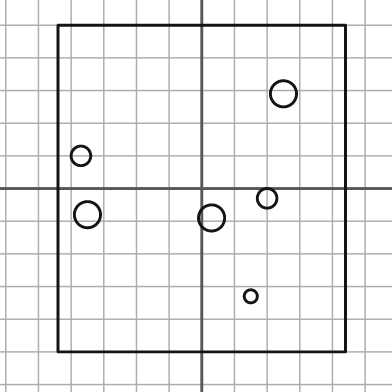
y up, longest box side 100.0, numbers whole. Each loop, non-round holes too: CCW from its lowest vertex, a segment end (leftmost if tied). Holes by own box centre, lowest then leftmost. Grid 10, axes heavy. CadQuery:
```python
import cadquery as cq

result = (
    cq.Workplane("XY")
    .moveTo(-44.0, -50.0)
    .lineTo(44.0, -50.0)
    .lineTo(44.0, 50.0)
    .lineTo(-44.0, 50.0)
    .close()
    .moveTo(15.0, -33.0)
    .circle(2.0)
    .moveTo(3.0, -9.0)
    .circle(4.0)
    .moveTo(-35.0, -8.0)
    .circle(4.0)
    .moveTo(20.0, -3.0)
    .circle(3.0)
    .moveTo(-37.0, 10.0)
    .circle(3.0)
    .moveTo(25.0, 29.0)
    .circle(4.0)
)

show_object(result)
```